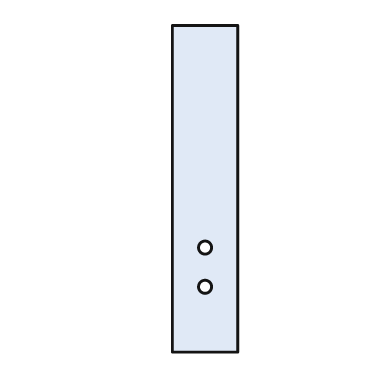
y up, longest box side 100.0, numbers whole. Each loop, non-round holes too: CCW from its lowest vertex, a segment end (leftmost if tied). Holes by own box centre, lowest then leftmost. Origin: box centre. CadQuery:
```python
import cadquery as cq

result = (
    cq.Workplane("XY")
    .moveTo(-10.0, -50.0)
    .lineTo(10.0, -50.0)
    .lineTo(10.0, 50.0)
    .lineTo(-10.0, 50.0)
    .close()
    .moveTo(0.0, -30.0)
    .circle(2.0)
    .moveTo(0.0, -18.0)
    .circle(2.0)
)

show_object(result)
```